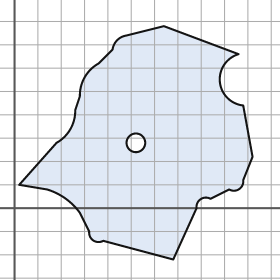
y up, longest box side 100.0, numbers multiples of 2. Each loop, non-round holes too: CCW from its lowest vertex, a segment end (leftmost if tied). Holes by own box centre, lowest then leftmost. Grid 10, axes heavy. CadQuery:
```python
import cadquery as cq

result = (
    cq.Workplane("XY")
    .moveTo(68.0, -22.0)
    .lineTo(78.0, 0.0)
    .threePointArc((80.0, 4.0), (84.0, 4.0))
    .lineTo(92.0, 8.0)
    .threePointArc((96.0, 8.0), (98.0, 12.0))
    .lineTo(102.0, 22.0)
    .lineTo(98.0, 44.0)
    .threePointArc((88.0, 54.0), (96.0, 66.0))
    .lineTo(64.0, 78.0)
    .lineTo(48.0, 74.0)
    .threePointArc((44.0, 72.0), (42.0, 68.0))
    .lineTo(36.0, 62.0)
    .threePointArc((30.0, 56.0), (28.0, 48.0))
    .lineTo(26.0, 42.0)
    .threePointArc((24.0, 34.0), (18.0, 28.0))
    .lineTo(2.0, 10.0)
    .lineTo(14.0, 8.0)
    .threePointArc((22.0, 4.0), (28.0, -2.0))
    .lineTo(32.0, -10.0)
    .threePointArc((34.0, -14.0), (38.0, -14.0))
    .close()
    .moveTo(52.0, 28.0)
    .circle(4.0)
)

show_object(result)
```